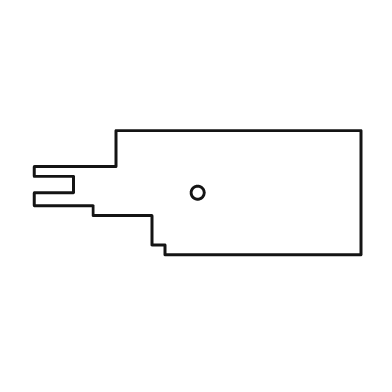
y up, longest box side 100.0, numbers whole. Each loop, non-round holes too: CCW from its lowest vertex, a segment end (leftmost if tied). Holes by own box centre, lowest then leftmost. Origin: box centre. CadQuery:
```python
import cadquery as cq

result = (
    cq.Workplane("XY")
    .moveTo(-10.0, -19.0)
    .lineTo(50.0, -19.0)
    .lineTo(50.0, 19.0)
    .lineTo(-25.0, 19.0)
    .lineTo(-25.0, 8.0)
    .lineTo(-50.0, 8.0)
    .lineTo(-50.0, 5.0)
    .lineTo(-38.0, 5.0)
    .lineTo(-38.0, 0.0)
    .lineTo(-50.0, 0.0)
    .lineTo(-50.0, -4.0)
    .lineTo(-32.0, -4.0)
    .lineTo(-32.0, -7.0)
    .lineTo(-14.0, -7.0)
    .lineTo(-14.0, -16.0)
    .lineTo(-10.0, -16.0)
    .close()
    .moveTo(0.0, 0.0)
    .circle(2.0)
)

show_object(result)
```